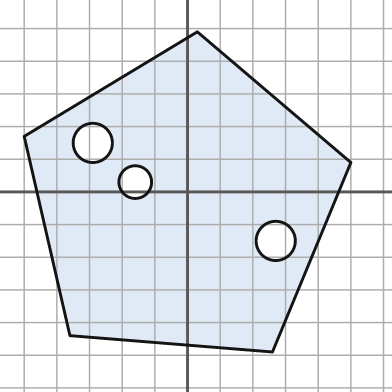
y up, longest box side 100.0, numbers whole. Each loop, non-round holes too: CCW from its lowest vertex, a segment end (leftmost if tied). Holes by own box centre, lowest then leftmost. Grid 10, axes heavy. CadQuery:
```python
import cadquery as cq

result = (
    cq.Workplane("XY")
    .moveTo(26.0, -49.0)
    .lineTo(50.0, 9.0)
    .lineTo(3.0, 49.0)
    .lineTo(-50.0, 17.0)
    .lineTo(-36.0, -44.0)
    .close()
    .moveTo(27.0, -15.0)
    .circle(6.0)
    .moveTo(-16.0, 3.0)
    .circle(5.0)
    .moveTo(-29.0, 15.0)
    .circle(6.0)
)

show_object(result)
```